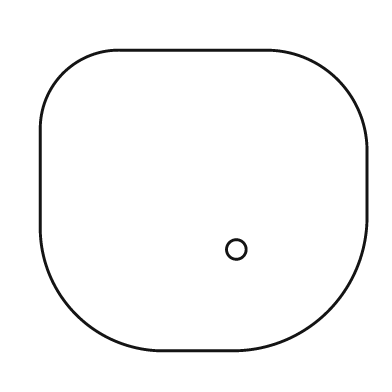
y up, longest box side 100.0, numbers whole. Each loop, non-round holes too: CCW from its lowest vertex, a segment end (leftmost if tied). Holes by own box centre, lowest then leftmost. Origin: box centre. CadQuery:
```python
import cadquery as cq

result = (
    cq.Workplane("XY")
    .moveTo(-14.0, -46.0)
    .lineTo(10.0, -46.0)
    .threePointArc((38.0, -34.0), (50.0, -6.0))
    .lineTo(50.0, 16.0)
    .threePointArc((41.0, 37.0), (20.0, 46.0))
    .lineTo(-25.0, 46.0)
    .threePointArc((-43.0, 39.0), (-50.0, 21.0))
    .lineTo(-50.0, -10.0)
    .threePointArc((-39.0, -35.0), (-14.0, -46.0))
    .close()
    .moveTo(10.0, -15.0)
    .circle(3.0)
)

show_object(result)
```